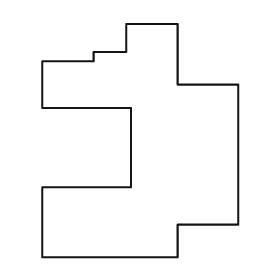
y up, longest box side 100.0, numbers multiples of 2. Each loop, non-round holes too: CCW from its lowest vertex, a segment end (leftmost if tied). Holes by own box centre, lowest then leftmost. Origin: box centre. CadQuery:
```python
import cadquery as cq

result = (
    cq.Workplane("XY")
    .moveTo(-42.0, -50.0)
    .lineTo(16.0, -50.0)
    .lineTo(16.0, -36.0)
    .lineTo(42.0, -36.0)
    .lineTo(42.0, 24.0)
    .lineTo(16.0, 24.0)
    .lineTo(16.0, 50.0)
    .lineTo(-6.0, 50.0)
    .lineTo(-6.0, 38.0)
    .lineTo(-20.0, 38.0)
    .lineTo(-20.0, 34.0)
    .lineTo(-42.0, 34.0)
    .lineTo(-42.0, 14.0)
    .lineTo(-4.0, 14.0)
    .lineTo(-4.0, -20.0)
    .lineTo(-42.0, -20.0)
    .close()
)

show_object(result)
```